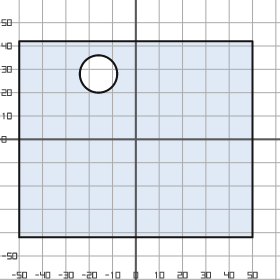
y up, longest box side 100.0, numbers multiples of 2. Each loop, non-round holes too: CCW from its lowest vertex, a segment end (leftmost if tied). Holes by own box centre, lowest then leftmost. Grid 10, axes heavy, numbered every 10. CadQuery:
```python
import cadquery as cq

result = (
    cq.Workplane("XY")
    .moveTo(-50.0, -42.0)
    .lineTo(50.0, -42.0)
    .lineTo(50.0, 42.0)
    .lineTo(-50.0, 42.0)
    .close()
    .moveTo(-16.0, 28.0)
    .circle(8.0)
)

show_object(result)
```